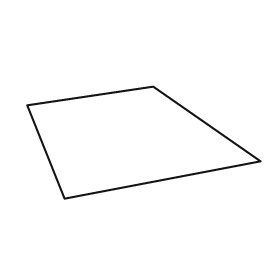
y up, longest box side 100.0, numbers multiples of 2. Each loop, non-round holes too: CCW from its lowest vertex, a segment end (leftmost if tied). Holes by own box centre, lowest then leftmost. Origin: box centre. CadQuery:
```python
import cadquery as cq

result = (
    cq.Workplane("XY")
    .moveTo(-34.0, -24.0)
    .lineTo(50.0, -8.0)
    .lineTo(4.0, 24.0)
    .lineTo(-50.0, 16.0)
    .close()
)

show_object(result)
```